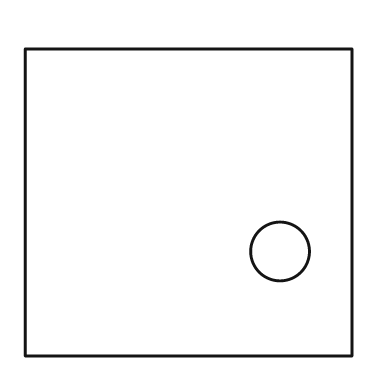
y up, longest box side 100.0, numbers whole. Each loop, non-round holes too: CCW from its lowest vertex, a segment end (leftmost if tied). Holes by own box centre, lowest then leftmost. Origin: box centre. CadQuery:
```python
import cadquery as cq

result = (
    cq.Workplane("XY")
    .moveTo(-50.0, -47.0)
    .lineTo(50.0, -47.0)
    .lineTo(50.0, 47.0)
    .lineTo(-50.0, 47.0)
    .close()
    .moveTo(28.0, -15.0)
    .circle(9.0)
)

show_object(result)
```